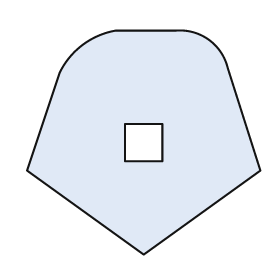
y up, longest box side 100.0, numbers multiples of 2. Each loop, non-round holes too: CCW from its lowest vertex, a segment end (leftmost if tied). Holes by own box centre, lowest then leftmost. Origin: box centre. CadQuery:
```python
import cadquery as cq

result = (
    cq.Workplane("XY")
    .moveTo(0.0, -48.0)
    .lineTo(50.0, -12.0)
    .lineTo(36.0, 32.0)
    .threePointArc((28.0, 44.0), (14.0, 48.0))
    .lineTo(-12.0, 48.0)
    .threePointArc((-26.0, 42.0), (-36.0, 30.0))
    .lineTo(-50.0, -12.0)
    .close()
    .moveTo(-8.0, -8.0)
    .lineTo(8.0, -8.0)
    .lineTo(8.0, 8.0)
    .lineTo(-8.0, 8.0)
    .close()
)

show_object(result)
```